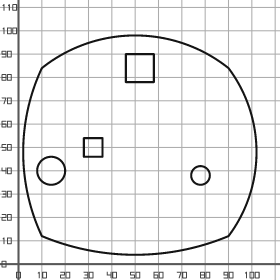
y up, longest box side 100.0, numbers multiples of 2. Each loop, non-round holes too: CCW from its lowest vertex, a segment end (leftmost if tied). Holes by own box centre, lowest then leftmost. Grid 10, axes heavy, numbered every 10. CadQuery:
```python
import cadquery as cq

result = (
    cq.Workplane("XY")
    .moveTo(10.0, 12.0)
    .threePointArc((50.0, 4.0), (90.0, 12.0))
    .threePointArc((102.0, 48.0), (90.0, 84.0))
    .threePointArc((50.0, 98.0), (10.0, 84.0))
    .threePointArc((2.0, 48.0), (10.0, 12.0))
    .close()
    .moveTo(78.0, 38.0)
    .circle(4.0)
    .moveTo(14.0, 40.0)
    .circle(6.0)
    .moveTo(28.0, 46.0)
    .lineTo(36.0, 46.0)
    .lineTo(36.0, 54.0)
    .lineTo(28.0, 54.0)
    .close()
    .moveTo(46.0, 78.0)
    .lineTo(58.0, 78.0)
    .lineTo(58.0, 90.0)
    .lineTo(46.0, 90.0)
    .close()
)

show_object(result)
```